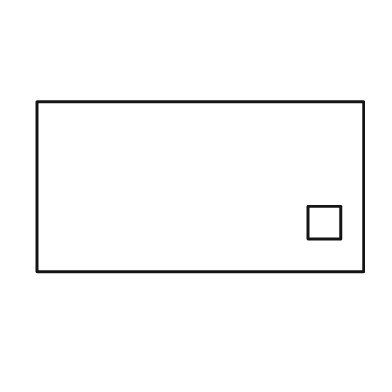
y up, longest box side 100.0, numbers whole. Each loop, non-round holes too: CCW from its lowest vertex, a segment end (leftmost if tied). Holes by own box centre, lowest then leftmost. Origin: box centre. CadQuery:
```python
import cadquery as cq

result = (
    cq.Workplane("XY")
    .moveTo(-50.0, -26.0)
    .lineTo(50.0, -26.0)
    .lineTo(50.0, 26.0)
    .lineTo(-50.0, 26.0)
    .close()
    .moveTo(33.0, -16.0)
    .lineTo(43.0, -16.0)
    .lineTo(43.0, -6.0)
    .lineTo(33.0, -6.0)
    .close()
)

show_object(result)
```